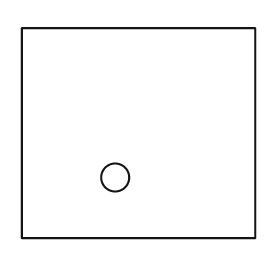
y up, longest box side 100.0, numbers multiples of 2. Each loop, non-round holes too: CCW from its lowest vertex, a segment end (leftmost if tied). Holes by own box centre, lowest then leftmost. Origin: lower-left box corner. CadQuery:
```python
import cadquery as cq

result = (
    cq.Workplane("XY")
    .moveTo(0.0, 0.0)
    .lineTo(100.0, 0.0)
    .lineTo(100.0, 90.0)
    .lineTo(0.0, 90.0)
    .close()
    .moveTo(40.0, 26.0)
    .circle(6.0)
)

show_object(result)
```